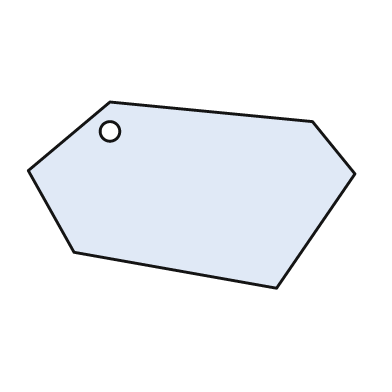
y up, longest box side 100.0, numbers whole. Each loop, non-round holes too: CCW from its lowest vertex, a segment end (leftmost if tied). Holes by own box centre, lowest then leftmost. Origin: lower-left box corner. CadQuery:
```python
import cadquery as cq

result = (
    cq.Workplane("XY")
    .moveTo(76.0, 0.0)
    .lineTo(100.0, 35.0)
    .lineTo(87.0, 51.0)
    .lineTo(25.0, 57.0)
    .lineTo(0.0, 36.0)
    .lineTo(14.0, 11.0)
    .close()
    .moveTo(25.0, 48.0)
    .circle(3.0)
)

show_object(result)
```